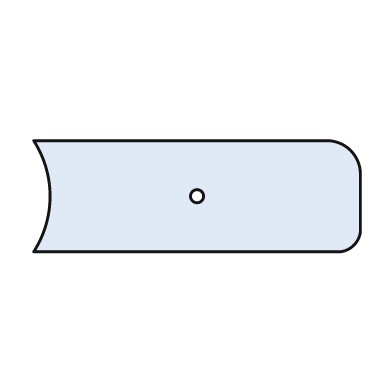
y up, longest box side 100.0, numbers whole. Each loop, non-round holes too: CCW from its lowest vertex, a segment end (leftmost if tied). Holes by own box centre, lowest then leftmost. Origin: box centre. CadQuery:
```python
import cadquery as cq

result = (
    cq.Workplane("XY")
    .moveTo(-50.0, -17.0)
    .lineTo(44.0, -17.0)
    .threePointArc((48.0, -15.0), (50.0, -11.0))
    .lineTo(50.0, 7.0)
    .threePointArc((47.0, 14.0), (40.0, 17.0))
    .lineTo(-50.0, 17.0)
    .threePointArc((-45.0, 0.0), (-50.0, -17.0))
    .close()
    .moveTo(0.0, 0.0)
    .circle(2.0)
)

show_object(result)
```